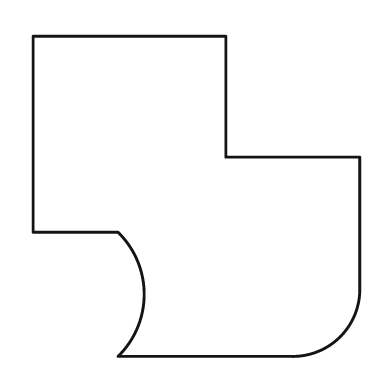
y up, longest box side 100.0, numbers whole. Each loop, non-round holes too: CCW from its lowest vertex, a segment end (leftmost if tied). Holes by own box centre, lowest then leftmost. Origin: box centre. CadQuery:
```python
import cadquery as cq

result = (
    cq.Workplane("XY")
    .moveTo(-24.0, -49.0)
    .lineTo(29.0, -49.0)
    .threePointArc((44.0, -43.0), (50.0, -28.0))
    .lineTo(50.0, 12.0)
    .lineTo(9.0, 12.0)
    .lineTo(9.0, 49.0)
    .lineTo(-50.0, 49.0)
    .lineTo(-50.0, -11.0)
    .lineTo(-24.0, -11.0)
    .threePointArc((-16.0, -30.0), (-24.0, -49.0))
    .close()
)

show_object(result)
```